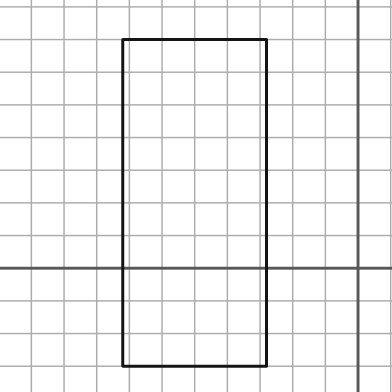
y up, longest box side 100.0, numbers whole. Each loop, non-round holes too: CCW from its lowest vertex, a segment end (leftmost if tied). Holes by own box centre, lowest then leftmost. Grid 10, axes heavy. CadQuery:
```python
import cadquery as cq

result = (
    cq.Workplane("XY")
    .moveTo(-72.0, -30.0)
    .lineTo(-28.0, -30.0)
    .lineTo(-28.0, 70.0)
    .lineTo(-72.0, 70.0)
    .close()
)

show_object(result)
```